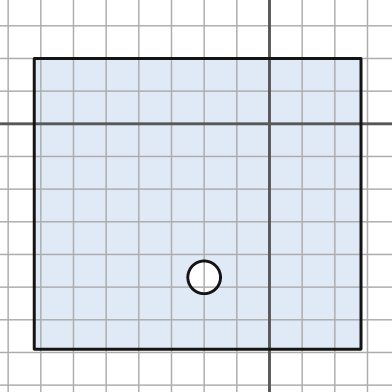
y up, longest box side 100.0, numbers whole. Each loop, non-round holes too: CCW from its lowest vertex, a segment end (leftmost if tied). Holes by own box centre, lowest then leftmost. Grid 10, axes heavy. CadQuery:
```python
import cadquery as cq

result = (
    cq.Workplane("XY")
    .moveTo(-72.0, -69.0)
    .lineTo(28.0, -69.0)
    .lineTo(28.0, 20.0)
    .lineTo(-72.0, 20.0)
    .close()
    .moveTo(-20.0, -47.0)
    .circle(5.0)
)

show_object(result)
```